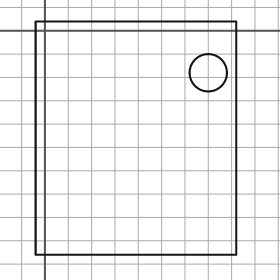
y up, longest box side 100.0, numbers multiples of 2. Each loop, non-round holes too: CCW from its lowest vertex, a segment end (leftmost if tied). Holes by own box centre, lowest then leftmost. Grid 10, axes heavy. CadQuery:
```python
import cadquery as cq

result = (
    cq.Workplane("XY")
    .moveTo(-4.0, -96.0)
    .lineTo(82.0, -96.0)
    .lineTo(82.0, 4.0)
    .lineTo(-4.0, 4.0)
    .close()
    .moveTo(70.0, -18.0)
    .circle(8.0)
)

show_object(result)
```